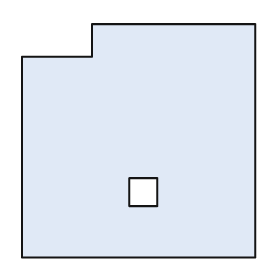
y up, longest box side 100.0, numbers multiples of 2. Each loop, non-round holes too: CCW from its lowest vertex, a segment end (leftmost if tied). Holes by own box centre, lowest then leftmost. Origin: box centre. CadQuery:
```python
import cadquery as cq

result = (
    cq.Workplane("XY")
    .moveTo(-50.0, -50.0)
    .lineTo(50.0, -50.0)
    .lineTo(50.0, 50.0)
    .lineTo(-20.0, 50.0)
    .lineTo(-20.0, 36.0)
    .lineTo(-50.0, 36.0)
    .close()
    .moveTo(-4.0, -28.0)
    .lineTo(8.0, -28.0)
    .lineTo(8.0, -16.0)
    .lineTo(-4.0, -16.0)
    .close()
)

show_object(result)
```